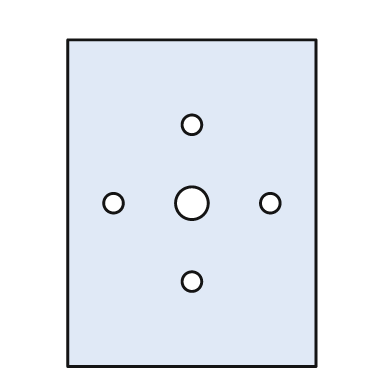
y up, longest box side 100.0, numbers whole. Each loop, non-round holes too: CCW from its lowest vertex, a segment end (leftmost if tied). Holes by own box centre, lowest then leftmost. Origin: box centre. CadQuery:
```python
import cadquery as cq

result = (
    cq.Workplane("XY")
    .moveTo(-38.0, -50.0)
    .lineTo(38.0, -50.0)
    .lineTo(38.0, 50.0)
    .lineTo(-38.0, 50.0)
    .close()
    .moveTo(0.0, -24.0)
    .circle(3.0)
    .moveTo(-24.0, 0.0)
    .circle(3.0)
    .moveTo(0.0, 0.0)
    .circle(5.0)
    .moveTo(24.0, 0.0)
    .circle(3.0)
    .moveTo(0.0, 24.0)
    .circle(3.0)
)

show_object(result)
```